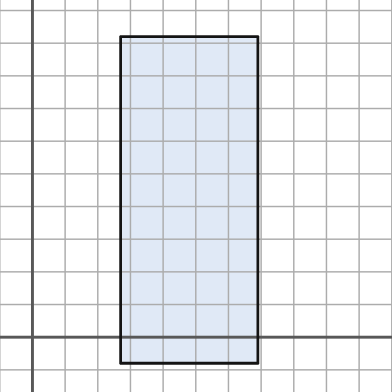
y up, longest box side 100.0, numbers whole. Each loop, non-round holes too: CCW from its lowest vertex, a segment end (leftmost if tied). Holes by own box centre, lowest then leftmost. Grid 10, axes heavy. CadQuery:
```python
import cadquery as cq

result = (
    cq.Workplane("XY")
    .moveTo(27.0, -8.0)
    .lineTo(69.0, -8.0)
    .lineTo(69.0, 92.0)
    .lineTo(27.0, 92.0)
    .close()
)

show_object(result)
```